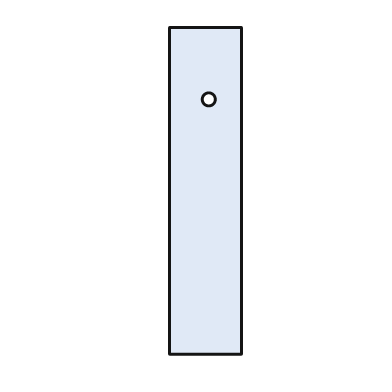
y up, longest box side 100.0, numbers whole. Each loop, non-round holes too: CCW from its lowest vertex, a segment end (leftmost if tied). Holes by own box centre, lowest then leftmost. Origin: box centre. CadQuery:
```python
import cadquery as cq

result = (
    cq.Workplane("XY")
    .moveTo(-11.0, -50.0)
    .lineTo(11.0, -50.0)
    .lineTo(11.0, 50.0)
    .lineTo(-11.0, 50.0)
    .close()
    .moveTo(1.0, 28.0)
    .circle(2.0)
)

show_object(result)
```